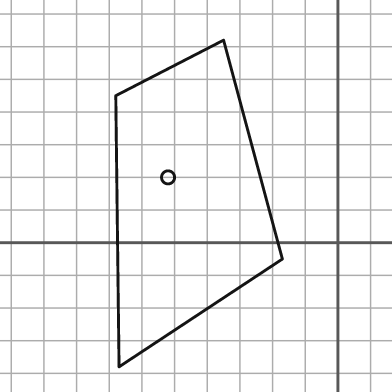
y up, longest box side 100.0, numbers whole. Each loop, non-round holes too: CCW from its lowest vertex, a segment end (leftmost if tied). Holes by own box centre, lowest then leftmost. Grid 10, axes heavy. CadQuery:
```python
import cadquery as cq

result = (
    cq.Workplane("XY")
    .moveTo(-67.0, -38.0)
    .lineTo(-17.0, -5.0)
    .lineTo(-35.0, 62.0)
    .lineTo(-68.0, 45.0)
    .close()
    .moveTo(-52.0, 20.0)
    .circle(2.0)
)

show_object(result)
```